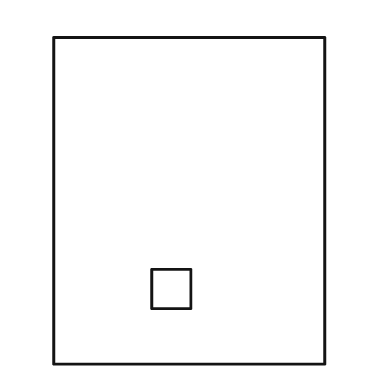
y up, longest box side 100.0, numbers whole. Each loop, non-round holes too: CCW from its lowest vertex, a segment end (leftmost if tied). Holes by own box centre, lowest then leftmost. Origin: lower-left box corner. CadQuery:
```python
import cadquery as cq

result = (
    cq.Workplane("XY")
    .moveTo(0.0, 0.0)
    .lineTo(83.0, 0.0)
    .lineTo(83.0, 100.0)
    .lineTo(0.0, 100.0)
    .close()
    .moveTo(30.0, 17.0)
    .lineTo(42.0, 17.0)
    .lineTo(42.0, 29.0)
    .lineTo(30.0, 29.0)
    .close()
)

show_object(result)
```